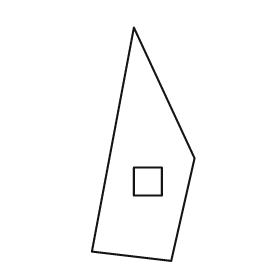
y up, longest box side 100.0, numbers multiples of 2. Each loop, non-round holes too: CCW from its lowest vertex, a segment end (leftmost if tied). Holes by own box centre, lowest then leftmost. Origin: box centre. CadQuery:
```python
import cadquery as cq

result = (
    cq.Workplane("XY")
    .moveTo(12.0, -50.0)
    .lineTo(22.0, -6.0)
    .lineTo(-4.0, 50.0)
    .lineTo(-22.0, -46.0)
    .close()
    .moveTo(-4.0, -22.0)
    .lineTo(8.0, -22.0)
    .lineTo(8.0, -10.0)
    .lineTo(-4.0, -10.0)
    .close()
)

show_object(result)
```